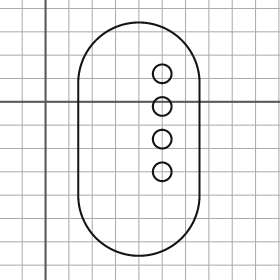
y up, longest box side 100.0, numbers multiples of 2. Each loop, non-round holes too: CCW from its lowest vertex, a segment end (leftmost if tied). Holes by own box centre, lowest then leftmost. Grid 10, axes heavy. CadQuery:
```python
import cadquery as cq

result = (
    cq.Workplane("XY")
    .moveTo(14.0, -40.0)
    .threePointArc((40.0, -66.0), (66.0, -40.0))
    .lineTo(66.0, 8.0)
    .threePointArc((40.0, 34.0), (14.0, 8.0))
    .close()
    .moveTo(50.0, -30.0)
    .circle(4.0)
    .moveTo(50.0, -16.0)
    .circle(4.0)
    .moveTo(50.0, -2.0)
    .circle(4.0)
    .moveTo(50.0, 12.0)
    .circle(4.0)
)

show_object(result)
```